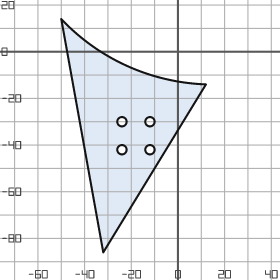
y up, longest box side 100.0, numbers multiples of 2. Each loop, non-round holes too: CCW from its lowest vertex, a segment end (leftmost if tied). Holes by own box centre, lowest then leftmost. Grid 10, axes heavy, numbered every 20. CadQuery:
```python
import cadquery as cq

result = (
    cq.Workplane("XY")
    .moveTo(-32.0, -86.0)
    .lineTo(12.0, -14.0)
    .threePointArc((-22.0, -6.0), (-50.0, 14.0))
    .close()
    .moveTo(-24.0, -42.0)
    .circle(2.0)
    .moveTo(-12.0, -42.0)
    .circle(2.0)
    .moveTo(-24.0, -30.0)
    .circle(2.0)
    .moveTo(-12.0, -30.0)
    .circle(2.0)
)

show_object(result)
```